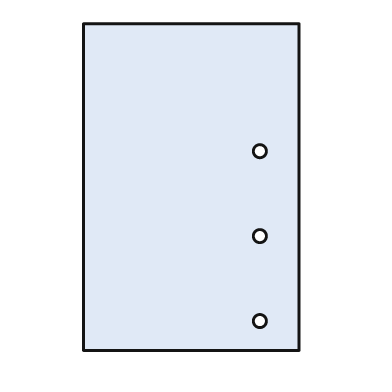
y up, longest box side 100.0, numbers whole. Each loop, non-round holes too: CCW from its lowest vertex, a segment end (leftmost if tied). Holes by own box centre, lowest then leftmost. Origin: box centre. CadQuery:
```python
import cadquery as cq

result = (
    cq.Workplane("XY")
    .moveTo(-33.0, -50.0)
    .lineTo(33.0, -50.0)
    .lineTo(33.0, 50.0)
    .lineTo(-33.0, 50.0)
    .close()
    .moveTo(21.0, -41.0)
    .circle(2.0)
    .moveTo(21.0, -15.0)
    .circle(2.0)
    .moveTo(21.0, 11.0)
    .circle(2.0)
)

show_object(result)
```